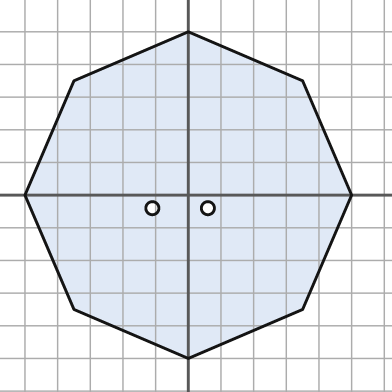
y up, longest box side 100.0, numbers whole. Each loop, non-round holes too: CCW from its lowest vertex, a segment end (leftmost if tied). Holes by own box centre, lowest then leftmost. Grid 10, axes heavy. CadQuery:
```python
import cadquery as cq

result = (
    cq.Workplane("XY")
    .moveTo(0.0, -50.0)
    .lineTo(35.0, -35.0)
    .lineTo(50.0, 0.0)
    .lineTo(35.0, 35.0)
    .lineTo(0.0, 50.0)
    .lineTo(-35.0, 35.0)
    .lineTo(-50.0, 0.0)
    .lineTo(-35.0, -35.0)
    .close()
    .moveTo(-11.0, -4.0)
    .circle(2.0)
    .moveTo(6.0, -4.0)
    .circle(2.0)
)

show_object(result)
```